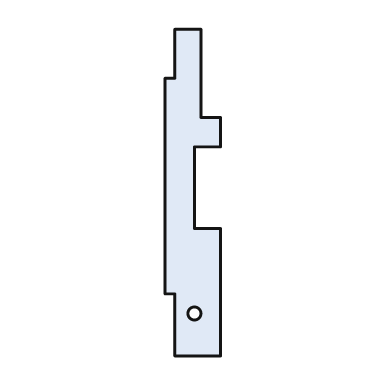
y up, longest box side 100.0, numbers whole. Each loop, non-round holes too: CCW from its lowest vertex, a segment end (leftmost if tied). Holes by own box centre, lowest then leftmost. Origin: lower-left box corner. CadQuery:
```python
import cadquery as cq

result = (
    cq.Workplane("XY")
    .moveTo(3.0, 0.0)
    .lineTo(17.0, 0.0)
    .lineTo(17.0, 39.0)
    .lineTo(9.0, 39.0)
    .lineTo(9.0, 64.0)
    .lineTo(17.0, 64.0)
    .lineTo(17.0, 73.0)
    .lineTo(11.0, 73.0)
    .lineTo(11.0, 100.0)
    .lineTo(3.0, 100.0)
    .lineTo(3.0, 85.0)
    .lineTo(0.0, 85.0)
    .lineTo(0.0, 19.0)
    .lineTo(3.0, 19.0)
    .close()
    .moveTo(9.0, 13.0)
    .circle(2.0)
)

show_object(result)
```